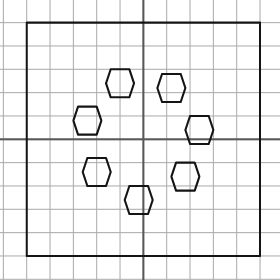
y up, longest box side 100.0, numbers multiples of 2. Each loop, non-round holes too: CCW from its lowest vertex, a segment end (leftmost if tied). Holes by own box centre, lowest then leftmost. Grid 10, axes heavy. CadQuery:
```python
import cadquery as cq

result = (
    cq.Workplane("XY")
    .moveTo(-50.0, -50.0)
    .lineTo(50.0, -50.0)
    .lineTo(50.0, 50.0)
    .lineTo(-50.0, 50.0)
    .close()
    .moveTo(-6.0, -32.0)
    .lineTo(2.0, -32.0)
    .lineTo(4.0, -26.0)
    .lineTo(2.0, -20.0)
    .lineTo(-6.0, -20.0)
    .lineTo(-8.0, -26.0)
    .close()
    .moveTo(14.0, -22.0)
    .lineTo(22.0, -22.0)
    .lineTo(24.0, -16.0)
    .lineTo(22.0, -10.0)
    .lineTo(14.0, -10.0)
    .lineTo(12.0, -16.0)
    .close()
    .moveTo(-24.0, -20.0)
    .lineTo(-16.0, -20.0)
    .lineTo(-14.0, -14.0)
    .lineTo(-16.0, -8.0)
    .lineTo(-24.0, -8.0)
    .lineTo(-26.0, -14.0)
    .close()
    .moveTo(20.0, -2.0)
    .lineTo(28.0, -2.0)
    .lineTo(30.0, 4.0)
    .lineTo(28.0, 10.0)
    .lineTo(20.0, 10.0)
    .lineTo(18.0, 4.0)
    .close()
    .moveTo(-28.0, 2.0)
    .lineTo(-20.0, 2.0)
    .lineTo(-18.0, 8.0)
    .lineTo(-20.0, 14.0)
    .lineTo(-28.0, 14.0)
    .lineTo(-30.0, 8.0)
    .close()
    .moveTo(8.0, 16.0)
    .lineTo(16.0, 16.0)
    .lineTo(18.0, 22.0)
    .lineTo(16.0, 28.0)
    .lineTo(8.0, 28.0)
    .lineTo(6.0, 22.0)
    .close()
    .moveTo(-14.0, 18.0)
    .lineTo(-6.0, 18.0)
    .lineTo(-4.0, 24.0)
    .lineTo(-6.0, 30.0)
    .lineTo(-14.0, 30.0)
    .lineTo(-16.0, 24.0)
    .close()
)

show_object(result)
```